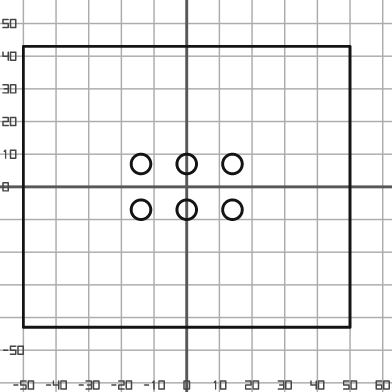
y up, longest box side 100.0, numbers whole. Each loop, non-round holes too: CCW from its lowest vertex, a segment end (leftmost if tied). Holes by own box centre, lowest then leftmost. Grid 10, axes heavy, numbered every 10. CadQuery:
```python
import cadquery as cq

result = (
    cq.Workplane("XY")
    .moveTo(-50.0, -43.0)
    .lineTo(50.0, -43.0)
    .lineTo(50.0, 43.0)
    .lineTo(-50.0, 43.0)
    .close()
    .moveTo(-14.0, -7.0)
    .circle(3.0)
    .moveTo(0.0, -7.0)
    .circle(3.0)
    .moveTo(14.0, -7.0)
    .circle(3.0)
    .moveTo(-14.0, 7.0)
    .circle(3.0)
    .moveTo(0.0, 7.0)
    .circle(3.0)
    .moveTo(14.0, 7.0)
    .circle(3.0)
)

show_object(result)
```